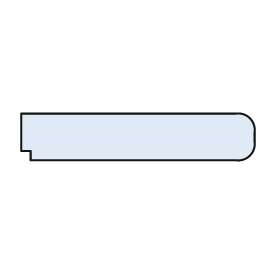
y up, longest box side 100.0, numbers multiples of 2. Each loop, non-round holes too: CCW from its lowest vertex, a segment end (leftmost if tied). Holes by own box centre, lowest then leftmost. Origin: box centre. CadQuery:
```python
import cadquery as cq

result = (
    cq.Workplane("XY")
    .moveTo(-46.0, -10.0)
    .lineTo(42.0, -10.0)
    .threePointArc((48.0, -8.0), (50.0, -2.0))
    .lineTo(50.0, 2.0)
    .threePointArc((48.0, 8.0), (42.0, 10.0))
    .lineTo(-50.0, 10.0)
    .lineTo(-50.0, -6.0)
    .lineTo(-46.0, -6.0)
    .close()
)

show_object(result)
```